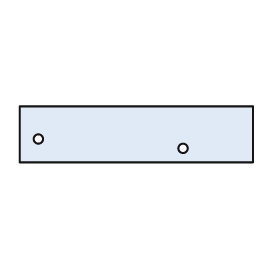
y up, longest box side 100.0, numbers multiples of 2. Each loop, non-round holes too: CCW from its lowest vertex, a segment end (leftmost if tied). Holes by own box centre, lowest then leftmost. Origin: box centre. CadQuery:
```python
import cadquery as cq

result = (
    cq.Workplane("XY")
    .moveTo(-50.0, -12.0)
    .lineTo(50.0, -12.0)
    .lineTo(50.0, 12.0)
    .lineTo(-50.0, 12.0)
    .close()
    .moveTo(20.0, -6.0)
    .circle(2.0)
    .moveTo(-42.0, -2.0)
    .circle(2.0)
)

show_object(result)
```